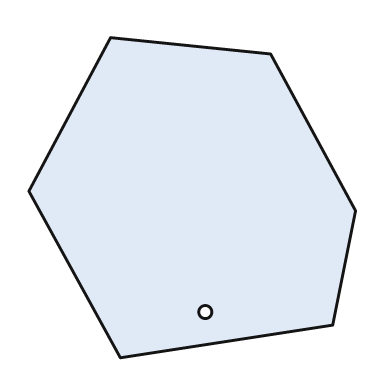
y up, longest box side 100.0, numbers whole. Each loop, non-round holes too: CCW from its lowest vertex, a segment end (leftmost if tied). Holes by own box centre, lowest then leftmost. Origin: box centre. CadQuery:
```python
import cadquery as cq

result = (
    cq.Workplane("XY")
    .moveTo(-22.0, -49.0)
    .lineTo(43.0, -39.0)
    .lineTo(50.0, -4.0)
    .lineTo(24.0, 44.0)
    .lineTo(-25.0, 49.0)
    .lineTo(-50.0, 2.0)
    .close()
    .moveTo(4.0, -35.0)
    .circle(2.0)
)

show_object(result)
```